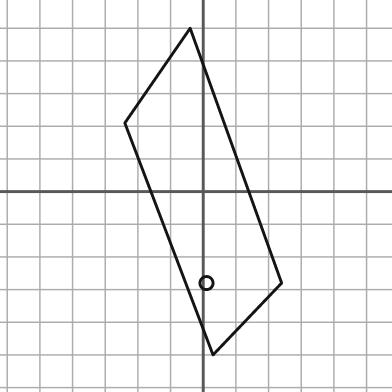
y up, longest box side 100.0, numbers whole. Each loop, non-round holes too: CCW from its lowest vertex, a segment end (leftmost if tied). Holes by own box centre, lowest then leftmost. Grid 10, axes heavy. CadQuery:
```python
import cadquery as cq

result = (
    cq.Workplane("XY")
    .moveTo(3.0, -50.0)
    .lineTo(24.0, -28.0)
    .lineTo(-4.0, 50.0)
    .lineTo(-24.0, 21.0)
    .close()
    .moveTo(1.0, -28.0)
    .circle(2.0)
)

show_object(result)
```